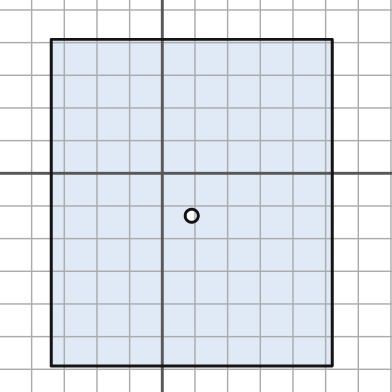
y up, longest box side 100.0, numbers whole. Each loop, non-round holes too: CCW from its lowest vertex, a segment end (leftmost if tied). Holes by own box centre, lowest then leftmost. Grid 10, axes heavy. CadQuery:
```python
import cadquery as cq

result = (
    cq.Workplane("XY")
    .moveTo(-34.0, -59.0)
    .lineTo(52.0, -59.0)
    .lineTo(52.0, 41.0)
    .lineTo(-34.0, 41.0)
    .close()
    .moveTo(9.0, -13.0)
    .circle(2.0)
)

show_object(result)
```